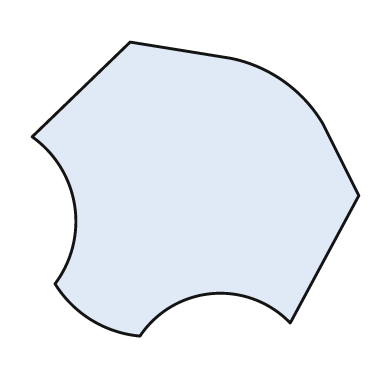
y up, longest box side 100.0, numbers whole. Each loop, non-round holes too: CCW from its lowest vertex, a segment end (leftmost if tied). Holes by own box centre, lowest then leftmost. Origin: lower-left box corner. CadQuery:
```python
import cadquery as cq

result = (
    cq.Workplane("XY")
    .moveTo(33.0, 0.0)
    .threePointArc((55.0, 13.0), (79.0, 4.0))
    .lineTo(100.0, 43.0)
    .lineTo(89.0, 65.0)
    .threePointArc((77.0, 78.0), (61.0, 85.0))
    .lineTo(30.0, 90.0)
    .lineTo(0.0, 61.0)
    .threePointArc((13.0, 40.0), (7.0, 16.0))
    .threePointArc((18.0, 5.0), (33.0, 0.0))
    .close()
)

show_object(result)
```